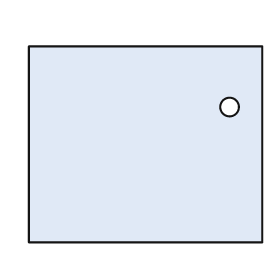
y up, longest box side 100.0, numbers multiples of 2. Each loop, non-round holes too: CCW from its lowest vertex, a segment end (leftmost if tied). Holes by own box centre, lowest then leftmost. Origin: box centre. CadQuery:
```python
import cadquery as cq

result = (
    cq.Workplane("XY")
    .moveTo(-50.0, -42.0)
    .lineTo(50.0, -42.0)
    .lineTo(50.0, 42.0)
    .lineTo(-50.0, 42.0)
    .close()
    .moveTo(36.0, 16.0)
    .circle(4.0)
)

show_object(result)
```